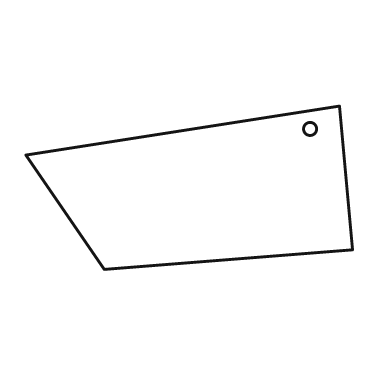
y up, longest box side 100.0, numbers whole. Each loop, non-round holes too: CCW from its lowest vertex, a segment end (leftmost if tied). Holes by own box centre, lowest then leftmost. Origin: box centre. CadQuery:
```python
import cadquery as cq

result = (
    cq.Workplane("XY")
    .moveTo(-26.0, -25.0)
    .lineTo(50.0, -19.0)
    .lineTo(46.0, 25.0)
    .lineTo(-50.0, 10.0)
    .close()
    .moveTo(37.0, 18.0)
    .circle(2.0)
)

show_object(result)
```